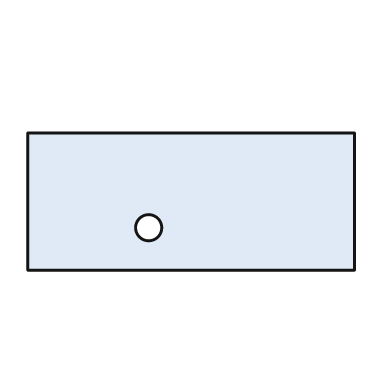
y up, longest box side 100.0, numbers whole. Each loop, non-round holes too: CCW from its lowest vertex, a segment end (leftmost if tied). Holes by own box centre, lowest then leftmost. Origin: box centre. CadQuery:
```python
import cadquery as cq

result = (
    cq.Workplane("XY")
    .moveTo(-50.0, -21.0)
    .lineTo(50.0, -21.0)
    .lineTo(50.0, 21.0)
    .lineTo(-50.0, 21.0)
    .close()
    .moveTo(-13.0, -8.0)
    .circle(4.0)
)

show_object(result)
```